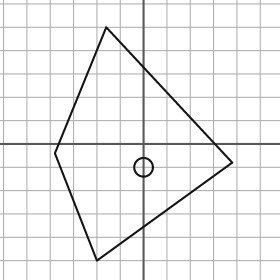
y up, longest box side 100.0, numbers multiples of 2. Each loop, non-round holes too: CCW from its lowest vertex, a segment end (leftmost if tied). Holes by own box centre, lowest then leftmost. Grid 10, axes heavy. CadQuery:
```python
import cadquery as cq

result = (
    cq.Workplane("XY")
    .moveTo(-20.0, -50.0)
    .lineTo(38.0, -8.0)
    .lineTo(-16.0, 50.0)
    .lineTo(-38.0, -4.0)
    .close()
    .moveTo(0.0, -10.0)
    .circle(4.0)
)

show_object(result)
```